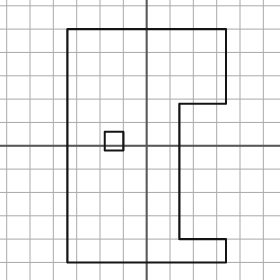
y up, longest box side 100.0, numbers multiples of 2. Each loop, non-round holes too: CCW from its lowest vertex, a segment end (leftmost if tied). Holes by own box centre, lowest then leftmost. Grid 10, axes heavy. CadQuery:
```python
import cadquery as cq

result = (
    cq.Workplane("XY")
    .moveTo(-34.0, -50.0)
    .lineTo(34.0, -50.0)
    .lineTo(34.0, -40.0)
    .lineTo(14.0, -40.0)
    .lineTo(14.0, 18.0)
    .lineTo(34.0, 18.0)
    .lineTo(34.0, 50.0)
    .lineTo(-34.0, 50.0)
    .close()
    .moveTo(-18.0, -2.0)
    .lineTo(-10.0, -2.0)
    .lineTo(-10.0, 6.0)
    .lineTo(-18.0, 6.0)
    .close()
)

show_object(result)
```